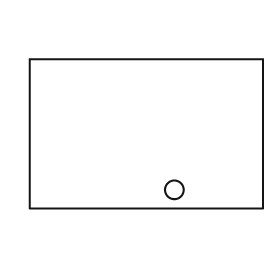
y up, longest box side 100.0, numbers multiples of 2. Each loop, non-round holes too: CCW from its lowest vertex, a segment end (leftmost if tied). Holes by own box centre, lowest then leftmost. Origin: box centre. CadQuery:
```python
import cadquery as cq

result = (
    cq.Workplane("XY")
    .moveTo(-50.0, -32.0)
    .lineTo(50.0, -32.0)
    .lineTo(50.0, 32.0)
    .lineTo(-50.0, 32.0)
    .close()
    .moveTo(12.0, -24.0)
    .circle(4.0)
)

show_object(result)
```